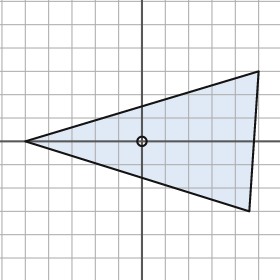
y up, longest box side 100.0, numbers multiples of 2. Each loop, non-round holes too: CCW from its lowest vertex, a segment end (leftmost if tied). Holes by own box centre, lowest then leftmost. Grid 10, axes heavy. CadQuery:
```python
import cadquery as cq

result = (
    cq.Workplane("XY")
    .moveTo(46.0, -30.0)
    .lineTo(50.0, 30.0)
    .lineTo(-50.0, 0.0)
    .close()
    .moveTo(0.0, 0.0)
    .circle(2.0)
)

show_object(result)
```